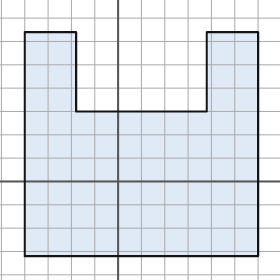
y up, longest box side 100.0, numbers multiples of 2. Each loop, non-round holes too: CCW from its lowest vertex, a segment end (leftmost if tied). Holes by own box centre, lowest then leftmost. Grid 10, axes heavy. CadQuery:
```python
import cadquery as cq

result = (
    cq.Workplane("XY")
    .moveTo(-40.0, -32.0)
    .lineTo(60.0, -32.0)
    .lineTo(60.0, 64.0)
    .lineTo(38.0, 64.0)
    .lineTo(38.0, 30.0)
    .lineTo(-18.0, 30.0)
    .lineTo(-18.0, 64.0)
    .lineTo(-40.0, 64.0)
    .close()
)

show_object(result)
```